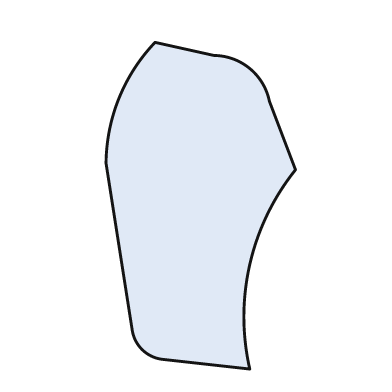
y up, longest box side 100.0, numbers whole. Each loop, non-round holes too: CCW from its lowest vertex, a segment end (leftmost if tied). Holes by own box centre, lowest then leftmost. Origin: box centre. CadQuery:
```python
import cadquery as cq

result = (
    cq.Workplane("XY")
    .moveTo(15.0, -50.0)
    .threePointArc((15.0, -18.0), (29.0, 11.0))
    .lineTo(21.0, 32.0)
    .threePointArc((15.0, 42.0), (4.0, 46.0))
    .lineTo(-14.0, 50.0)
    .threePointArc((-25.0, 33.0), (-29.0, 13.0))
    .lineTo(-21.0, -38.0)
    .threePointArc((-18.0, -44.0), (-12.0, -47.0))
    .close()
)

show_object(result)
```